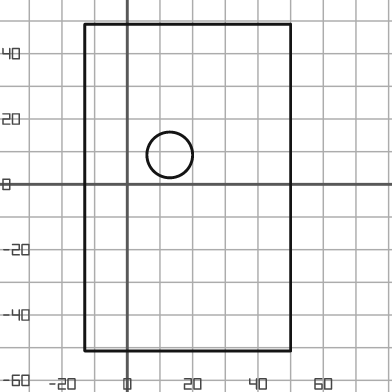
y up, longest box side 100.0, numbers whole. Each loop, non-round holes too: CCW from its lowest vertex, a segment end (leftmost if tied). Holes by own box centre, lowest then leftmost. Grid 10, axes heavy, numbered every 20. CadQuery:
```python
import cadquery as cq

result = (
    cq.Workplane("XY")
    .moveTo(-13.0, -51.0)
    .lineTo(50.0, -51.0)
    .lineTo(50.0, 49.0)
    .lineTo(-13.0, 49.0)
    .close()
    .moveTo(13.0, 9.0)
    .circle(7.0)
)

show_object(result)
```